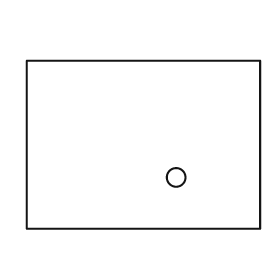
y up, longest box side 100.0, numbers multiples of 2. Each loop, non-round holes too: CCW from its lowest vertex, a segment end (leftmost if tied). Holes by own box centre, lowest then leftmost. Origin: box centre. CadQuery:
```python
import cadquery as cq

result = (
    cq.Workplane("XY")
    .moveTo(-50.0, -36.0)
    .lineTo(50.0, -36.0)
    .lineTo(50.0, 36.0)
    .lineTo(-50.0, 36.0)
    .close()
    .moveTo(14.0, -14.0)
    .circle(4.0)
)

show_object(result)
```